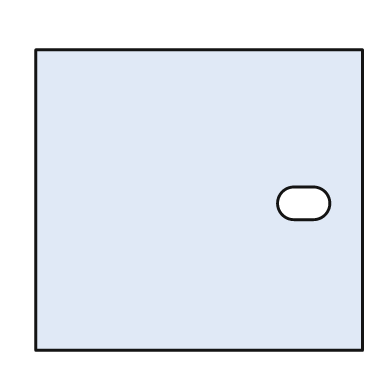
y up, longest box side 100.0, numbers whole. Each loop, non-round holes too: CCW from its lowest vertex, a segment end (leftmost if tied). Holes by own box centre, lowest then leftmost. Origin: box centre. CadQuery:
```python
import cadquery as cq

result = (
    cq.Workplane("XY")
    .moveTo(-50.0, -46.0)
    .lineTo(50.0, -46.0)
    .lineTo(50.0, 46.0)
    .lineTo(-50.0, 46.0)
    .close()
    .moveTo(29.0, -6.0)
    .lineTo(35.0, -6.0)
    .threePointArc((40.0, -1.0), (35.0, 4.0))
    .lineTo(29.0, 4.0)
    .threePointArc((24.0, -1.0), (29.0, -6.0))
    .close()
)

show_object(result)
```